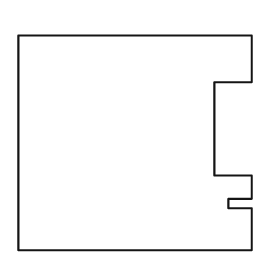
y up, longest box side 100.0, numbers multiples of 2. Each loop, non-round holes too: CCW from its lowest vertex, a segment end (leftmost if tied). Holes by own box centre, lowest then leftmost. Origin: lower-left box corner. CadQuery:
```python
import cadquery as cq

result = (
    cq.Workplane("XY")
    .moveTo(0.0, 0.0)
    .lineTo(100.0, 0.0)
    .lineTo(100.0, 18.0)
    .lineTo(90.0, 18.0)
    .lineTo(90.0, 22.0)
    .lineTo(100.0, 22.0)
    .lineTo(100.0, 32.0)
    .lineTo(84.0, 32.0)
    .lineTo(84.0, 72.0)
    .lineTo(100.0, 72.0)
    .lineTo(100.0, 92.0)
    .lineTo(0.0, 92.0)
    .close()
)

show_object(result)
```